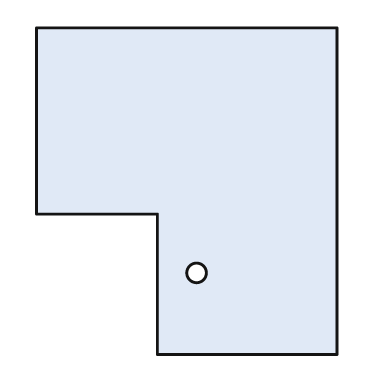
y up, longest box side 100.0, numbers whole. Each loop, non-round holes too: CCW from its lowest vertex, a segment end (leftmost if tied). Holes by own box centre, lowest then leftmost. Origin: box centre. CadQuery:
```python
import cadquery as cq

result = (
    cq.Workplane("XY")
    .moveTo(-9.0, -50.0)
    .lineTo(46.0, -50.0)
    .lineTo(46.0, 50.0)
    .lineTo(-46.0, 50.0)
    .lineTo(-46.0, -7.0)
    .lineTo(-9.0, -7.0)
    .close()
    .moveTo(3.0, -25.0)
    .circle(3.0)
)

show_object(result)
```